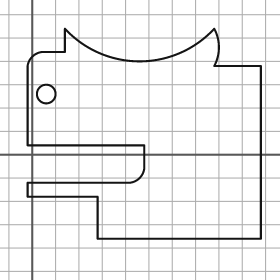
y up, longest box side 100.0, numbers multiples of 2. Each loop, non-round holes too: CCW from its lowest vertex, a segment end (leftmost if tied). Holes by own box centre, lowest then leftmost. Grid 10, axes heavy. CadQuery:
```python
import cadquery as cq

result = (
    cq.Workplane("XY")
    .moveTo(28.0, -36.0)
    .lineTo(98.0, -36.0)
    .lineTo(98.0, 38.0)
    .lineTo(78.0, 38.0)
    .threePointArc((80.0, 46.0), (78.0, 54.0))
    .threePointArc((46.0, 40.0), (14.0, 54.0))
    .lineTo(14.0, 44.0)
    .lineTo(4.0, 44.0)
    .threePointArc((0.0, 42.0), (-2.0, 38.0))
    .lineTo(-2.0, 4.0)
    .lineTo(48.0, 4.0)
    .lineTo(48.0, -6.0)
    .threePointArc((46.0, -10.0), (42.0, -12.0))
    .lineTo(-2.0, -12.0)
    .lineTo(-2.0, -18.0)
    .lineTo(28.0, -18.0)
    .close()
    .moveTo(6.0, 26.0)
    .circle(4.0)
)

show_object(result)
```